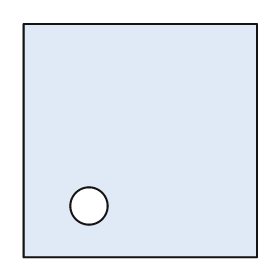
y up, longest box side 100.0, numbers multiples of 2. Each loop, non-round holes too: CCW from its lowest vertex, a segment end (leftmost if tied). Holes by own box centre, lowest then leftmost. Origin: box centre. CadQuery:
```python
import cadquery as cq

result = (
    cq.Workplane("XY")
    .moveTo(-50.0, -50.0)
    .lineTo(50.0, -50.0)
    .lineTo(50.0, 50.0)
    .lineTo(-50.0, 50.0)
    .close()
    .moveTo(-22.0, -28.0)
    .circle(8.0)
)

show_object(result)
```